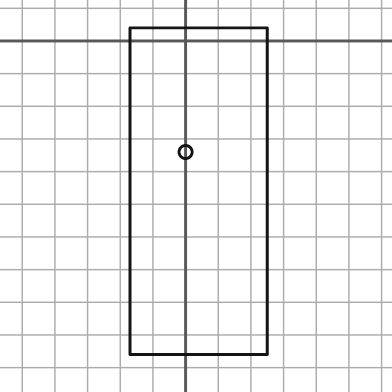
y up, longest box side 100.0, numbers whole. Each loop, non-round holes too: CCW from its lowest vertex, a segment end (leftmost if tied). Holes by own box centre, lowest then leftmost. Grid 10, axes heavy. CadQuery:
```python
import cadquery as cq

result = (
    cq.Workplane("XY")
    .moveTo(-17.0, -96.0)
    .lineTo(25.0, -96.0)
    .lineTo(25.0, 4.0)
    .lineTo(-17.0, 4.0)
    .close()
    .moveTo(0.0, -34.0)
    .circle(2.0)
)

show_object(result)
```